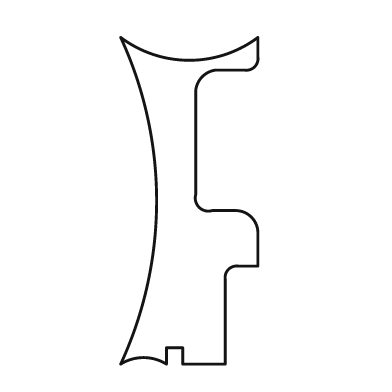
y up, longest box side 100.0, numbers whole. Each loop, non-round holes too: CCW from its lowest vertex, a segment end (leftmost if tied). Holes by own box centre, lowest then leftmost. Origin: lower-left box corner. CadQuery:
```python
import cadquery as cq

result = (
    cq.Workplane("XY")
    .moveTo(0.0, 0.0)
    .threePointArc((7.0, 2.0), (14.0, 0.0))
    .lineTo(14.0, 5.0)
    .lineTo(19.0, 5.0)
    .lineTo(19.0, 0.0)
    .lineTo(32.0, 0.0)
    .lineTo(32.0, 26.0)
    .threePointArc((33.0, 29.0), (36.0, 30.0))
    .lineTo(42.0, 30.0)
    .lineTo(42.0, 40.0)
    .threePointArc((40.0, 45.0), (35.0, 47.0))
    .lineTo(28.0, 47.0)
    .threePointArc((24.0, 48.0), (23.0, 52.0))
    .lineTo(23.0, 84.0)
    .threePointArc((25.0, 88.0), (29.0, 90.0))
    .lineTo(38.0, 90.0)
    .threePointArc((41.0, 91.0), (42.0, 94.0))
    .lineTo(42.0, 100.0)
    .threePointArc((21.0, 93.0), (0.0, 100.0))
    .threePointArc((11.0, 50.0), (0.0, 0.0))
    .close()
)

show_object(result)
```